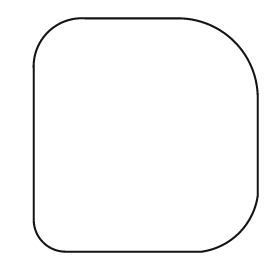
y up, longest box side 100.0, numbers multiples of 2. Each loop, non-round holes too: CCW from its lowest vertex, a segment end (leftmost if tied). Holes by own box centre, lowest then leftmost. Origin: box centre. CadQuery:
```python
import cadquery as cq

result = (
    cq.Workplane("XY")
    .moveTo(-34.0, -50.0)
    .lineTo(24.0, -50.0)
    .threePointArc((40.0, -42.0), (48.0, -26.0))
    .lineTo(48.0, 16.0)
    .threePointArc((38.0, 40.0), (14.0, 50.0))
    .lineTo(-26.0, 50.0)
    .threePointArc((-42.0, 44.0), (-48.0, 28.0))
    .lineTo(-48.0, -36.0)
    .threePointArc((-44.0, -46.0), (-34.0, -50.0))
    .close()
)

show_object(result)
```